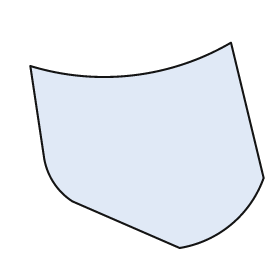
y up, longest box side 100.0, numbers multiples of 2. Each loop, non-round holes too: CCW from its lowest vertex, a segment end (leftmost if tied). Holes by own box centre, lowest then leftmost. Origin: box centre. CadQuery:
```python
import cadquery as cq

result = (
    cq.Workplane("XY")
    .moveTo(14.0, -44.0)
    .threePointArc((36.0, -34.0), (50.0, -14.0))
    .lineTo(36.0, 44.0)
    .threePointArc((-6.0, 30.0), (-50.0, 34.0))
    .lineTo(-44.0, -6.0)
    .threePointArc((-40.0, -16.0), (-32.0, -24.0))
    .close()
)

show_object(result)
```